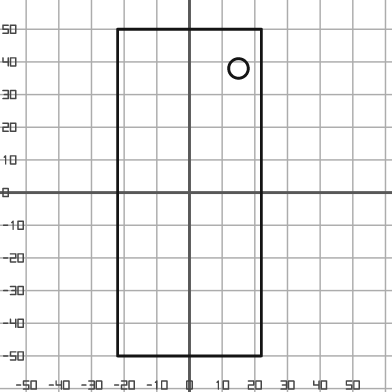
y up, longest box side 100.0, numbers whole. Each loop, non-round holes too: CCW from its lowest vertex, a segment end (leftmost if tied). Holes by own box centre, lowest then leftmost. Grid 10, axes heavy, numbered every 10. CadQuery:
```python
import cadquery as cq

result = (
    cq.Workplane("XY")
    .moveTo(-22.0, -50.0)
    .lineTo(22.0, -50.0)
    .lineTo(22.0, 50.0)
    .lineTo(-22.0, 50.0)
    .close()
    .moveTo(15.0, 38.0)
    .circle(3.0)
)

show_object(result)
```